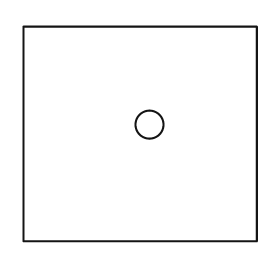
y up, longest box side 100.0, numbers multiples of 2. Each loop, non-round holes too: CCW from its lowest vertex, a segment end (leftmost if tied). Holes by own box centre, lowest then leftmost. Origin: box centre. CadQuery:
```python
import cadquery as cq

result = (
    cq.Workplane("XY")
    .moveTo(-50.0, -46.0)
    .lineTo(50.0, -46.0)
    .lineTo(50.0, 46.0)
    .lineTo(-50.0, 46.0)
    .close()
    .moveTo(4.0, 4.0)
    .circle(6.0)
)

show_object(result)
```